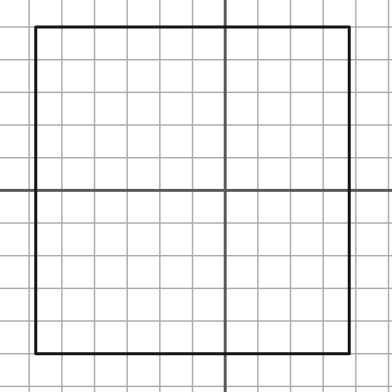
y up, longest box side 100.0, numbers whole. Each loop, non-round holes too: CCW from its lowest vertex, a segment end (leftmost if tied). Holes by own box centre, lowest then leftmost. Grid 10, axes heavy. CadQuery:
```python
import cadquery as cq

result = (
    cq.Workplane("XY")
    .moveTo(-58.0, -50.0)
    .lineTo(38.0, -50.0)
    .lineTo(38.0, 50.0)
    .lineTo(-58.0, 50.0)
    .close()
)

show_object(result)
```